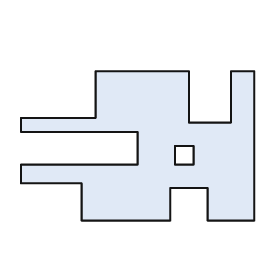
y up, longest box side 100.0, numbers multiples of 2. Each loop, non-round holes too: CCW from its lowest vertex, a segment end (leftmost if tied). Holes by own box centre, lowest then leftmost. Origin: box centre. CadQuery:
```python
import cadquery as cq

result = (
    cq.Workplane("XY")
    .moveTo(-24.0, -32.0)
    .lineTo(14.0, -32.0)
    .lineTo(14.0, -18.0)
    .lineTo(30.0, -18.0)
    .lineTo(30.0, -32.0)
    .lineTo(50.0, -32.0)
    .lineTo(50.0, 32.0)
    .lineTo(40.0, 32.0)
    .lineTo(40.0, 10.0)
    .lineTo(22.0, 10.0)
    .lineTo(22.0, 32.0)
    .lineTo(-18.0, 32.0)
    .lineTo(-18.0, 12.0)
    .lineTo(-50.0, 12.0)
    .lineTo(-50.0, 6.0)
    .lineTo(0.0, 6.0)
    .lineTo(0.0, -8.0)
    .lineTo(-50.0, -8.0)
    .lineTo(-50.0, -16.0)
    .lineTo(-24.0, -16.0)
    .close()
    .moveTo(16.0, -8.0)
    .lineTo(24.0, -8.0)
    .lineTo(24.0, 0.0)
    .lineTo(16.0, 0.0)
    .close()
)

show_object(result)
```